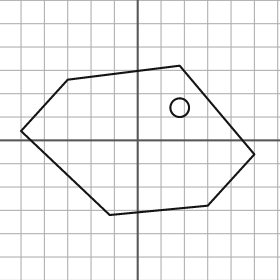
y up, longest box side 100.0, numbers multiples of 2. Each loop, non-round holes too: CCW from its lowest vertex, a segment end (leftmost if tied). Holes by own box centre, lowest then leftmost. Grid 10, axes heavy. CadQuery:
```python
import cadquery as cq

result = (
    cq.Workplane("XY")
    .moveTo(-12.0, -32.0)
    .lineTo(30.0, -28.0)
    .lineTo(50.0, -6.0)
    .lineTo(18.0, 32.0)
    .lineTo(-30.0, 26.0)
    .lineTo(-50.0, 4.0)
    .close()
    .moveTo(18.0, 14.0)
    .circle(4.0)
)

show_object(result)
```